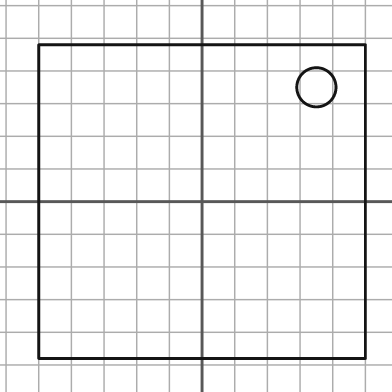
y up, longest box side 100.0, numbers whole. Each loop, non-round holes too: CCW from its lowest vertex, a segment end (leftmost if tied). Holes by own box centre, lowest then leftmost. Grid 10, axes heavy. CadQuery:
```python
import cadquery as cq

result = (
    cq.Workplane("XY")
    .moveTo(-50.0, -48.0)
    .lineTo(50.0, -48.0)
    .lineTo(50.0, 48.0)
    .lineTo(-50.0, 48.0)
    .close()
    .moveTo(35.0, 35.0)
    .circle(6.0)
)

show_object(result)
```